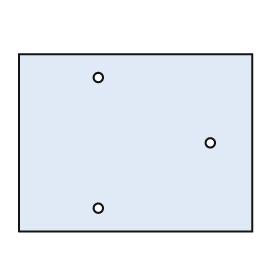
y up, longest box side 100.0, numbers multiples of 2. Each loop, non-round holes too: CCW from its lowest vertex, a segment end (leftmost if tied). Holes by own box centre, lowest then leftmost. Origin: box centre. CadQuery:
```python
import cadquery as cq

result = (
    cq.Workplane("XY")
    .moveTo(-50.0, -38.0)
    .lineTo(50.0, -38.0)
    .lineTo(50.0, 38.0)
    .lineTo(-50.0, 38.0)
    .close()
    .moveTo(-16.0, -28.0)
    .circle(2.0)
    .moveTo(32.0, 0.0)
    .circle(2.0)
    .moveTo(-16.0, 28.0)
    .circle(2.0)
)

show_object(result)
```